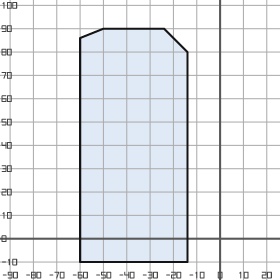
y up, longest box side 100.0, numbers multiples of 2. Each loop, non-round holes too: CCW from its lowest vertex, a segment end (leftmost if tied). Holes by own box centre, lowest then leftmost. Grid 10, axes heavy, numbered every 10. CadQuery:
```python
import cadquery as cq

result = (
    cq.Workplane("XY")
    .moveTo(-60.0, -10.0)
    .lineTo(-14.0, -10.0)
    .lineTo(-14.0, 80.0)
    .lineTo(-24.0, 90.0)
    .lineTo(-50.0, 90.0)
    .lineTo(-60.0, 86.0)
    .close()
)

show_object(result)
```